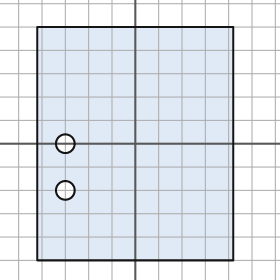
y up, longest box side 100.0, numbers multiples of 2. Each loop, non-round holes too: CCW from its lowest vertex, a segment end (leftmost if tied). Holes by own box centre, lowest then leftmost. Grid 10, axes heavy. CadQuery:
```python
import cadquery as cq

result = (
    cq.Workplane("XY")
    .moveTo(-42.0, -50.0)
    .lineTo(42.0, -50.0)
    .lineTo(42.0, 50.0)
    .lineTo(-42.0, 50.0)
    .close()
    .moveTo(-30.0, -20.0)
    .circle(4.0)
    .moveTo(-30.0, 0.0)
    .circle(4.0)
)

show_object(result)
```